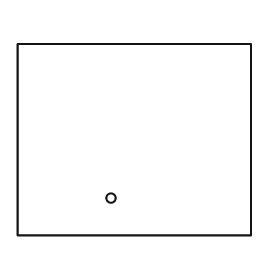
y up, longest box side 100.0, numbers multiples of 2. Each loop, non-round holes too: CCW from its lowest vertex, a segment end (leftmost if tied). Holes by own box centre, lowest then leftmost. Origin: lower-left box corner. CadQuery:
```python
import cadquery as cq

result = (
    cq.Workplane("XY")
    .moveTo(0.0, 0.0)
    .lineTo(100.0, 0.0)
    .lineTo(100.0, 82.0)
    .lineTo(0.0, 82.0)
    .close()
    .moveTo(40.0, 16.0)
    .circle(2.0)
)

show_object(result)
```